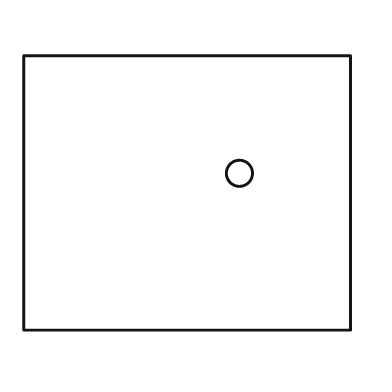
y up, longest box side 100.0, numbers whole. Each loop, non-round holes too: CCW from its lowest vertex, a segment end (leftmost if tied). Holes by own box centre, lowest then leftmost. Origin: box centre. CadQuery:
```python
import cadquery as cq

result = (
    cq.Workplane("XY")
    .moveTo(-50.0, -42.0)
    .lineTo(50.0, -42.0)
    .lineTo(50.0, 42.0)
    .lineTo(-50.0, 42.0)
    .close()
    .moveTo(16.0, 6.0)
    .circle(4.0)
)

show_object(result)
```